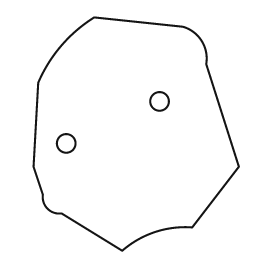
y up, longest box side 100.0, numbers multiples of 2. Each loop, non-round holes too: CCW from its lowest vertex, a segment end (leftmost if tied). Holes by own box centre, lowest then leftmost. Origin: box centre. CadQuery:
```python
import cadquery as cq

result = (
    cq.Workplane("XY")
    .moveTo(-6.0, -50.0)
    .threePointArc((8.0, -42.0), (24.0, -40.0))
    .lineTo(44.0, -14.0)
    .lineTo(30.0, 30.0)
    .threePointArc((28.0, 40.0), (20.0, 46.0))
    .lineTo(-18.0, 50.0)
    .threePointArc((-32.0, 38.0), (-42.0, 22.0))
    .lineTo(-44.0, -14.0)
    .lineTo(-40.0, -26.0)
    .threePointArc((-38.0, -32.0), (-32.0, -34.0))
    .close()
    .moveTo(-30.0, -4.0)
    .circle(4.0)
    .moveTo(10.0, 14.0)
    .circle(4.0)
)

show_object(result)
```